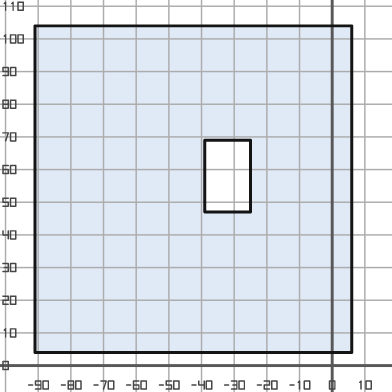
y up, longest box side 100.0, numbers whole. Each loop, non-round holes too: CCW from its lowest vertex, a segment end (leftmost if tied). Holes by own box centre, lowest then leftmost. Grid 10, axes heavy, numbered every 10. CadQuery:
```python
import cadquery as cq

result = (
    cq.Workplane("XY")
    .moveTo(-91.0, 4.0)
    .lineTo(6.0, 4.0)
    .lineTo(6.0, 104.0)
    .lineTo(-91.0, 104.0)
    .close()
    .moveTo(-39.0, 47.0)
    .lineTo(-25.0, 47.0)
    .lineTo(-25.0, 69.0)
    .lineTo(-39.0, 69.0)
    .close()
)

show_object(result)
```